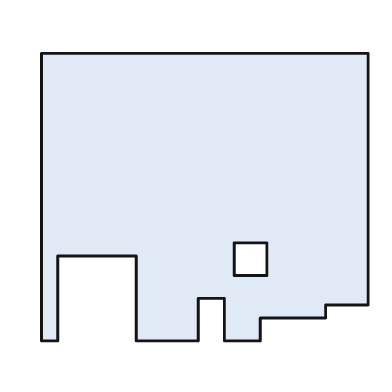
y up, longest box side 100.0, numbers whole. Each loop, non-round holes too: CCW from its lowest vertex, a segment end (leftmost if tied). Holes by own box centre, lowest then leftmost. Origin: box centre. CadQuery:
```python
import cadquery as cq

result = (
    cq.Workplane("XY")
    .moveTo(-50.0, -44.0)
    .lineTo(-45.0, -44.0)
    .lineTo(-45.0, -18.0)
    .lineTo(-21.0, -18.0)
    .lineTo(-21.0, -44.0)
    .lineTo(-2.0, -44.0)
    .lineTo(-2.0, -31.0)
    .lineTo(6.0, -31.0)
    .lineTo(6.0, -44.0)
    .lineTo(17.0, -44.0)
    .lineTo(17.0, -37.0)
    .lineTo(37.0, -37.0)
    .lineTo(37.0, -33.0)
    .lineTo(50.0, -33.0)
    .lineTo(50.0, 44.0)
    .lineTo(-50.0, 44.0)
    .close()
    .moveTo(9.0, -24.0)
    .lineTo(19.0, -24.0)
    .lineTo(19.0, -14.0)
    .lineTo(9.0, -14.0)
    .close()
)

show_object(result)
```